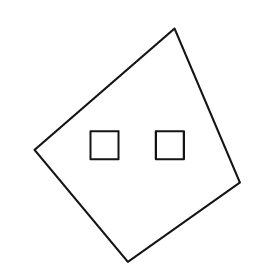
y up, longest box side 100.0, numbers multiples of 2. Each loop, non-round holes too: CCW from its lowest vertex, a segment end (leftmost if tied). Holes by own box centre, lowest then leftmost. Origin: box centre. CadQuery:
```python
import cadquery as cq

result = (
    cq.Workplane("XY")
    .moveTo(-4.0, -50.0)
    .lineTo(44.0, -16.0)
    .lineTo(16.0, 50.0)
    .lineTo(-44.0, -2.0)
    .close()
    .moveTo(-20.0, -6.0)
    .lineTo(-8.0, -6.0)
    .lineTo(-8.0, 6.0)
    .lineTo(-20.0, 6.0)
    .close()
    .moveTo(8.0, -6.0)
    .lineTo(20.0, -6.0)
    .lineTo(20.0, 6.0)
    .lineTo(8.0, 6.0)
    .close()
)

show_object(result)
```